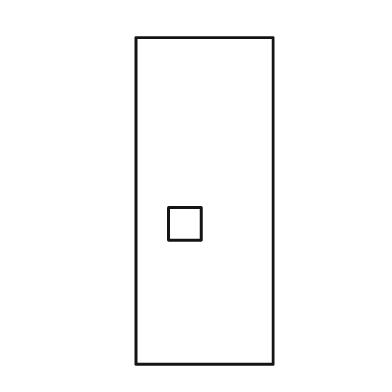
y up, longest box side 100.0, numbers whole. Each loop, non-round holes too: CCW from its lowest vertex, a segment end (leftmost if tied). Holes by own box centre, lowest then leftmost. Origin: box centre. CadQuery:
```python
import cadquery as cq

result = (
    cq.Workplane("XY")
    .moveTo(-21.0, -50.0)
    .lineTo(21.0, -50.0)
    .lineTo(21.0, 50.0)
    .lineTo(-21.0, 50.0)
    .close()
    .moveTo(-11.0, -12.0)
    .lineTo(-1.0, -12.0)
    .lineTo(-1.0, -2.0)
    .lineTo(-11.0, -2.0)
    .close()
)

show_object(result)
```